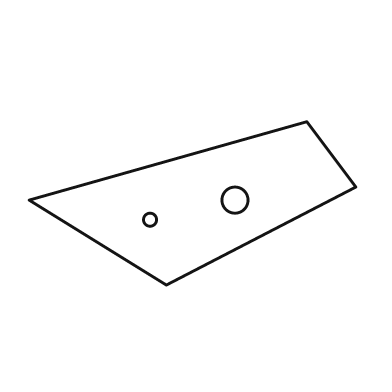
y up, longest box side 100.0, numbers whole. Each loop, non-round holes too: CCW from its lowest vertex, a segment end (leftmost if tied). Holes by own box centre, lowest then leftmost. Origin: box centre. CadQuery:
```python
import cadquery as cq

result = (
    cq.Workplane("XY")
    .moveTo(-8.0, -25.0)
    .lineTo(50.0, 5.0)
    .lineTo(35.0, 25.0)
    .lineTo(-50.0, 1.0)
    .close()
    .moveTo(-13.0, -5.0)
    .circle(2.0)
    .moveTo(13.0, 1.0)
    .circle(4.0)
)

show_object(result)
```